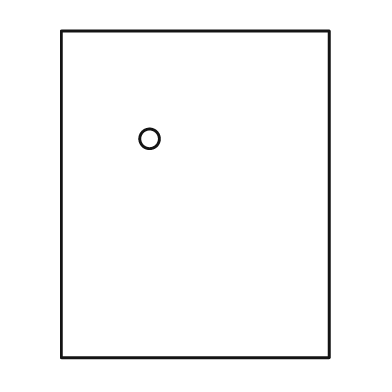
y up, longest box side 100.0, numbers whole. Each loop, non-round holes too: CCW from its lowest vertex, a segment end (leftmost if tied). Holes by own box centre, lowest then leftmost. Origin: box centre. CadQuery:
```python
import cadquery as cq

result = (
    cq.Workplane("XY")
    .moveTo(-41.0, -50.0)
    .lineTo(41.0, -50.0)
    .lineTo(41.0, 50.0)
    .lineTo(-41.0, 50.0)
    .close()
    .moveTo(-14.0, 17.0)
    .circle(3.0)
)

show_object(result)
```